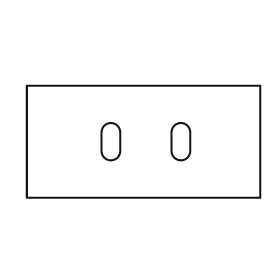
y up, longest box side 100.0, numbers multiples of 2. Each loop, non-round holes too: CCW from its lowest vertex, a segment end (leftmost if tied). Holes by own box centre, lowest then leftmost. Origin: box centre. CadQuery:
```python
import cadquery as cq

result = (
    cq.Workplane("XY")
    .moveTo(-50.0, -24.0)
    .lineTo(50.0, -24.0)
    .lineTo(50.0, 24.0)
    .lineTo(-50.0, 24.0)
    .close()
    .moveTo(-18.0, -4.0)
    .threePointArc((-14.0, -8.0), (-10.0, -4.0))
    .lineTo(-10.0, 4.0)
    .threePointArc((-14.0, 8.0), (-18.0, 4.0))
    .close()
    .moveTo(12.0, -4.0)
    .threePointArc((16.0, -8.0), (20.0, -4.0))
    .lineTo(20.0, 4.0)
    .threePointArc((16.0, 8.0), (12.0, 4.0))
    .close()
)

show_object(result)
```